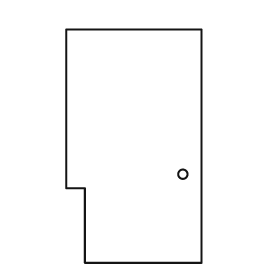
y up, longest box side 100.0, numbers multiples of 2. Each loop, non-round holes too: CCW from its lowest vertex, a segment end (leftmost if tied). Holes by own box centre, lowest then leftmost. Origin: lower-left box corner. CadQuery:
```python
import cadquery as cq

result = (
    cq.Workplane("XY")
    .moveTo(8.0, 0.0)
    .lineTo(58.0, 0.0)
    .lineTo(58.0, 100.0)
    .lineTo(0.0, 100.0)
    .lineTo(0.0, 32.0)
    .lineTo(8.0, 32.0)
    .close()
    .moveTo(50.0, 38.0)
    .circle(2.0)
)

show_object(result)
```